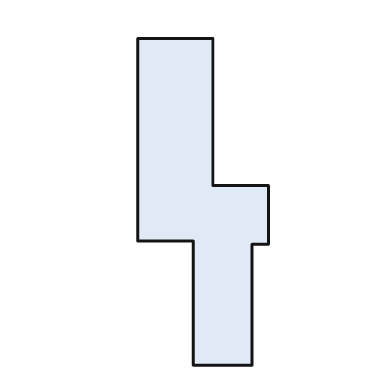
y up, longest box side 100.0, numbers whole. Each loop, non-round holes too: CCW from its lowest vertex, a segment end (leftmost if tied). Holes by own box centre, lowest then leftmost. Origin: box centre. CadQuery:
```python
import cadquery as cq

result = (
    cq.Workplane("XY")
    .moveTo(-3.0, -50.0)
    .lineTo(15.0, -50.0)
    .lineTo(15.0, -13.0)
    .lineTo(20.0, -13.0)
    .lineTo(20.0, 5.0)
    .lineTo(3.0, 5.0)
    .lineTo(3.0, 50.0)
    .lineTo(-20.0, 50.0)
    .lineTo(-20.0, -12.0)
    .lineTo(-3.0, -12.0)
    .close()
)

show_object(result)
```